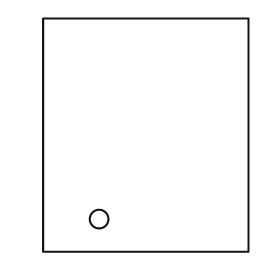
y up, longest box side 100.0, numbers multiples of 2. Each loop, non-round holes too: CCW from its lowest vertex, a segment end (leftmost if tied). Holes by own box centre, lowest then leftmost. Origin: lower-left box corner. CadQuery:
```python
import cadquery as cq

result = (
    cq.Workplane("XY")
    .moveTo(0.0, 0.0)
    .lineTo(88.0, 0.0)
    .lineTo(88.0, 100.0)
    .lineTo(0.0, 100.0)
    .close()
    .moveTo(24.0, 14.0)
    .circle(4.0)
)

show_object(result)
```